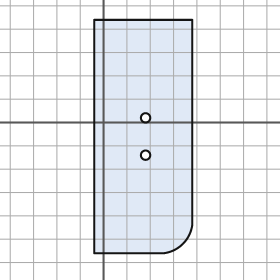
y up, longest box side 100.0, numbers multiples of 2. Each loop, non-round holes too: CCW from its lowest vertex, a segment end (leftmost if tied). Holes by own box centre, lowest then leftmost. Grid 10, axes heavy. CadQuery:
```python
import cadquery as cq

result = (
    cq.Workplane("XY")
    .moveTo(-4.0, -56.0)
    .lineTo(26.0, -56.0)
    .threePointArc((34.0, -52.0), (38.0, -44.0))
    .lineTo(38.0, 44.0)
    .lineTo(-4.0, 44.0)
    .close()
    .moveTo(18.0, -14.0)
    .circle(2.0)
    .moveTo(18.0, 2.0)
    .circle(2.0)
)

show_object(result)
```